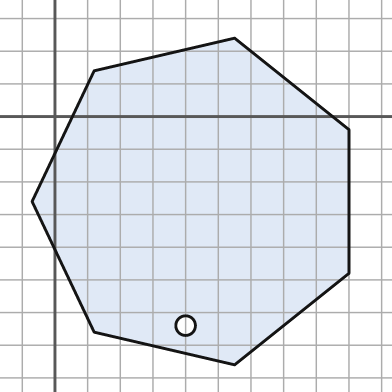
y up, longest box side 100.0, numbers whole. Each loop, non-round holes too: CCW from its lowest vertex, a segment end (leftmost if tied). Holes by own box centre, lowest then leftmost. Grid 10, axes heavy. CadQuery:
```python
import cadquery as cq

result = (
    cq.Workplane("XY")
    .moveTo(55.0, -76.0)
    .lineTo(90.0, -48.0)
    .lineTo(90.0, -4.0)
    .lineTo(55.0, 24.0)
    .lineTo(12.0, 14.0)
    .lineTo(-7.0, -26.0)
    .lineTo(12.0, -66.0)
    .close()
    .moveTo(40.0, -64.0)
    .circle(3.0)
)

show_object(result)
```